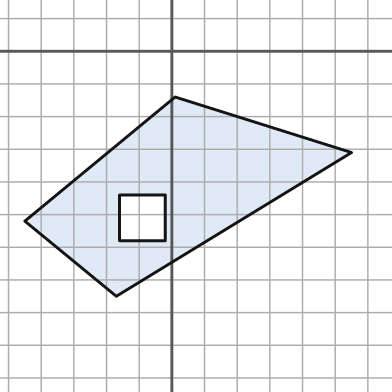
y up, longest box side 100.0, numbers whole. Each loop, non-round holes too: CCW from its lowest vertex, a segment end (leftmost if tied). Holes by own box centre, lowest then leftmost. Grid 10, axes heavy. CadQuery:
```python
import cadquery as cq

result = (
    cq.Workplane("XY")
    .moveTo(-17.0, -75.0)
    .lineTo(55.0, -31.0)
    .lineTo(1.0, -14.0)
    .lineTo(-45.0, -52.0)
    .close()
    .moveTo(-16.0, -58.0)
    .lineTo(-2.0, -58.0)
    .lineTo(-2.0, -44.0)
    .lineTo(-16.0, -44.0)
    .close()
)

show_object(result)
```